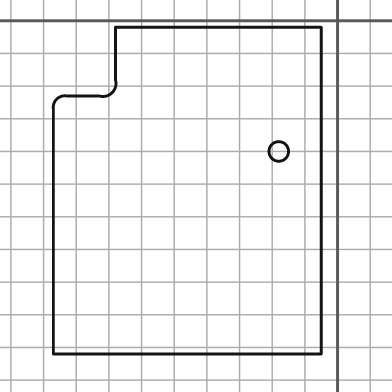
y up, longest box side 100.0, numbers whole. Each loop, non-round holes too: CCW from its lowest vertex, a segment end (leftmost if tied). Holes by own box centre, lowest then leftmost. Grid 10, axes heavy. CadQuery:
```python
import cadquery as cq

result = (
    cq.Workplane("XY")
    .moveTo(-87.0, -102.0)
    .lineTo(-5.0, -102.0)
    .lineTo(-5.0, -2.0)
    .lineTo(-68.0, -2.0)
    .lineTo(-68.0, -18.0)
    .threePointArc((-69.0, -22.0), (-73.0, -23.0))
    .lineTo(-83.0, -23.0)
    .threePointArc((-86.0, -24.0), (-87.0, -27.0))
    .close()
    .moveTo(-18.0, -40.0)
    .circle(3.0)
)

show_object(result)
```